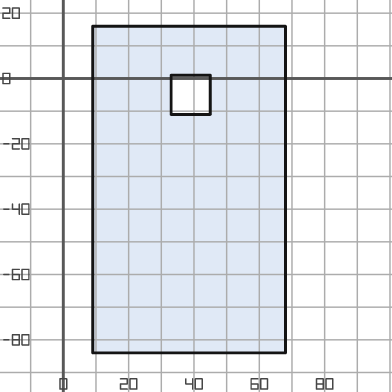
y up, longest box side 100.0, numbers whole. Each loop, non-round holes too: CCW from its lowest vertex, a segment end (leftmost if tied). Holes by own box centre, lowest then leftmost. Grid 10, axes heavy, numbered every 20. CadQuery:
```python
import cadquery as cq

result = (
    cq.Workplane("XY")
    .moveTo(9.0, -84.0)
    .lineTo(68.0, -84.0)
    .lineTo(68.0, 16.0)
    .lineTo(9.0, 16.0)
    .close()
    .moveTo(33.0, -11.0)
    .lineTo(45.0, -11.0)
    .lineTo(45.0, 1.0)
    .lineTo(33.0, 1.0)
    .close()
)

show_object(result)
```